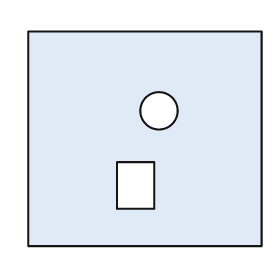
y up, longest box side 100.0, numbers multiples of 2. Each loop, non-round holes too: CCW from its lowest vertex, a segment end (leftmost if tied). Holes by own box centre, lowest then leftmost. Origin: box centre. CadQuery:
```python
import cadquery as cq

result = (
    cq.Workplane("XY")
    .moveTo(-50.0, -46.0)
    .lineTo(50.0, -46.0)
    .lineTo(50.0, 46.0)
    .lineTo(-50.0, 46.0)
    .close()
    .moveTo(-12.0, -30.0)
    .lineTo(4.0, -30.0)
    .lineTo(4.0, -10.0)
    .lineTo(-12.0, -10.0)
    .close()
    .moveTo(6.0, 12.0)
    .circle(8.0)
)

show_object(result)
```